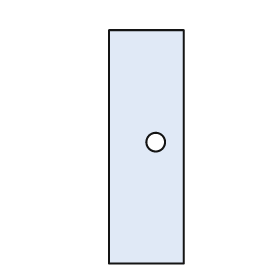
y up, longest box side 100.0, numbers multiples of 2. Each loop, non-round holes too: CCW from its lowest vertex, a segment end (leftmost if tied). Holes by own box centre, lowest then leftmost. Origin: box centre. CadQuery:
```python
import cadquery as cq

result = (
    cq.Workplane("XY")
    .moveTo(-16.0, -50.0)
    .lineTo(16.0, -50.0)
    .lineTo(16.0, 50.0)
    .lineTo(-16.0, 50.0)
    .close()
    .moveTo(4.0, 2.0)
    .circle(4.0)
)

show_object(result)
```